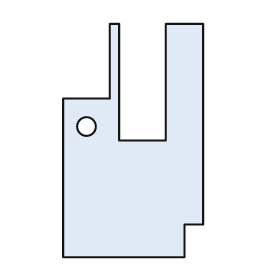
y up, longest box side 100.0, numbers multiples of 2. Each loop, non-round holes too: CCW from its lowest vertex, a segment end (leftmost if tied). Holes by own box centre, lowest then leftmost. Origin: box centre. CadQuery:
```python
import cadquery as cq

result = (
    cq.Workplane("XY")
    .moveTo(-30.0, -50.0)
    .lineTo(22.0, -50.0)
    .lineTo(22.0, -36.0)
    .lineTo(30.0, -36.0)
    .lineTo(30.0, 50.0)
    .lineTo(14.0, 50.0)
    .lineTo(14.0, 0.0)
    .lineTo(-6.0, 0.0)
    .lineTo(-6.0, 50.0)
    .lineTo(-10.0, 50.0)
    .lineTo(-10.0, 18.0)
    .lineTo(-30.0, 18.0)
    .close()
    .moveTo(-20.0, 6.0)
    .circle(4.0)
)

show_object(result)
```